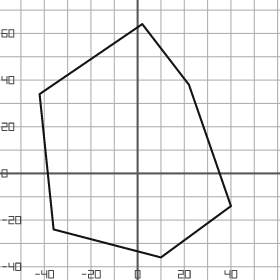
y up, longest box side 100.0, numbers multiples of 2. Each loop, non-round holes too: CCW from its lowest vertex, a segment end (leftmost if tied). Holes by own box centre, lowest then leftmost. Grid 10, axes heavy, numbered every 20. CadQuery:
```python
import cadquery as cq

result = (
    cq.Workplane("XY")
    .moveTo(10.0, -36.0)
    .lineTo(40.0, -14.0)
    .lineTo(22.0, 38.0)
    .lineTo(2.0, 64.0)
    .lineTo(-42.0, 34.0)
    .lineTo(-36.0, -24.0)
    .close()
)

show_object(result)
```